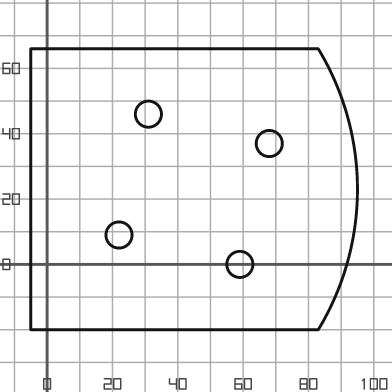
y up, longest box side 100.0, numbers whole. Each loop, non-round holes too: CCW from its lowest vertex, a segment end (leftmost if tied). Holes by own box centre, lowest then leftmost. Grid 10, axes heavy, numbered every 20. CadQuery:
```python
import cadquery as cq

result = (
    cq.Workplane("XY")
    .moveTo(-5.0, -20.0)
    .lineTo(83.0, -20.0)
    .threePointArc((95.0, 23.0), (83.0, 66.0))
    .lineTo(-5.0, 66.0)
    .close()
    .moveTo(59.0, 0.0)
    .circle(4.0)
    .moveTo(22.0, 9.0)
    .circle(4.0)
    .moveTo(68.0, 37.0)
    .circle(4.0)
    .moveTo(31.0, 46.0)
    .circle(4.0)
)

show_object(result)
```